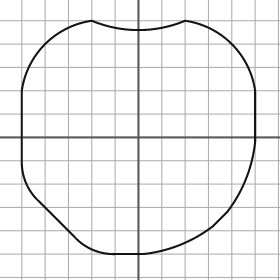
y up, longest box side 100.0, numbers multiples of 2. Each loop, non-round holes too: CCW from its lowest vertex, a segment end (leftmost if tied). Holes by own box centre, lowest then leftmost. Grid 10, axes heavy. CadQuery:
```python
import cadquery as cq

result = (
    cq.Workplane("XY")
    .moveTo(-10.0, -50.0)
    .lineTo(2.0, -50.0)
    .threePointArc((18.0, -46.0), (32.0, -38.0))
    .lineTo(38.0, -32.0)
    .threePointArc((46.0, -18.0), (50.0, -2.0))
    .lineTo(50.0, 20.0)
    .threePointArc((40.0, 40.0), (20.0, 50.0))
    .threePointArc((0.0, 46.0), (-20.0, 50.0))
    .threePointArc((-40.0, 40.0), (-50.0, 20.0))
    .lineTo(-50.0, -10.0)
    .threePointArc((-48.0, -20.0), (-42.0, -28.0))
    .lineTo(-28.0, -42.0)
    .threePointArc((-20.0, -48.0), (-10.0, -50.0))
    .close()
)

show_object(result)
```